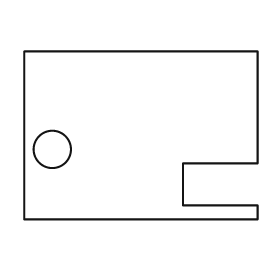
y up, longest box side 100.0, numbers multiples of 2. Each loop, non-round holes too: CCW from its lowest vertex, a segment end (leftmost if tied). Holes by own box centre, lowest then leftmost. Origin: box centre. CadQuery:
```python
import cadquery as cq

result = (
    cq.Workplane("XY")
    .moveTo(-50.0, -36.0)
    .lineTo(50.0, -36.0)
    .lineTo(50.0, -30.0)
    .lineTo(18.0, -30.0)
    .lineTo(18.0, -12.0)
    .lineTo(50.0, -12.0)
    .lineTo(50.0, 36.0)
    .lineTo(-50.0, 36.0)
    .close()
    .moveTo(-38.0, -6.0)
    .circle(8.0)
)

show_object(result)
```